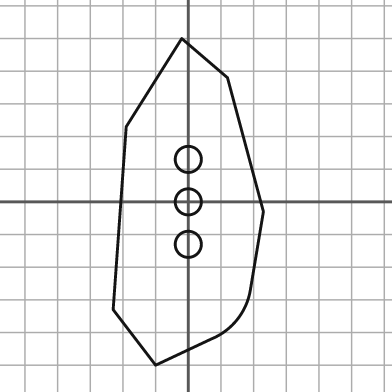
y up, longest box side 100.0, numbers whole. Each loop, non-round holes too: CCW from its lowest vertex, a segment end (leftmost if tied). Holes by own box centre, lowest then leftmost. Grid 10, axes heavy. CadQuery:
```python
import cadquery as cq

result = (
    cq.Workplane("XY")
    .moveTo(-10.0, -50.0)
    .lineTo(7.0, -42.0)
    .threePointArc((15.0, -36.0), (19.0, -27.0))
    .lineTo(23.0, -3.0)
    .lineTo(12.0, 38.0)
    .lineTo(-2.0, 50.0)
    .lineTo(-19.0, 23.0)
    .lineTo(-23.0, -33.0)
    .close()
    .moveTo(0.0, -13.0)
    .circle(4.0)
    .moveTo(0.0, 0.0)
    .circle(4.0)
    .moveTo(0.0, 13.0)
    .circle(4.0)
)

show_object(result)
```